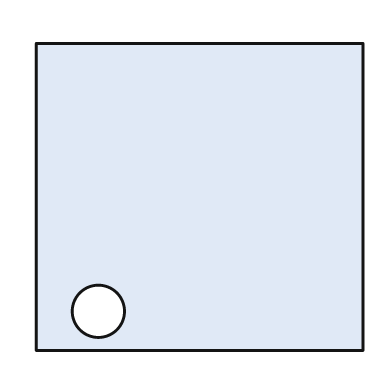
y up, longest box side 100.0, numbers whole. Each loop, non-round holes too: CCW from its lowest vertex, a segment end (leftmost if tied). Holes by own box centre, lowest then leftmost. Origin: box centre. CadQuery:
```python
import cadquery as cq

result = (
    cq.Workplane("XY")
    .moveTo(-50.0, -47.0)
    .lineTo(50.0, -47.0)
    .lineTo(50.0, 47.0)
    .lineTo(-50.0, 47.0)
    .close()
    .moveTo(-31.0, -35.0)
    .circle(8.0)
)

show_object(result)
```